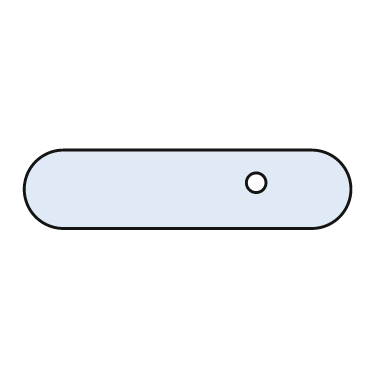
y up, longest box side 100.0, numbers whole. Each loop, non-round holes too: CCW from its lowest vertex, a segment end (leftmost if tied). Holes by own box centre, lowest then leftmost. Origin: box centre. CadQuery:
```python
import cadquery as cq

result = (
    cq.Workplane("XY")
    .moveTo(-38.0, -12.0)
    .lineTo(38.0, -12.0)
    .threePointArc((50.0, 0.0), (38.0, 12.0))
    .lineTo(-38.0, 12.0)
    .threePointArc((-50.0, 0.0), (-38.0, -12.0))
    .close()
    .moveTo(21.0, 2.0)
    .circle(3.0)
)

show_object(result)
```